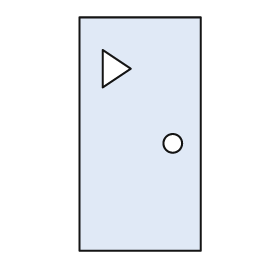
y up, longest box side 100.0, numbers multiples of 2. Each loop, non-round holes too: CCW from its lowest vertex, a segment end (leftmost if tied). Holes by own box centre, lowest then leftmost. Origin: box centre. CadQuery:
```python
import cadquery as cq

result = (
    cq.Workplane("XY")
    .moveTo(-26.0, -50.0)
    .lineTo(26.0, -50.0)
    .lineTo(26.0, 50.0)
    .lineTo(-26.0, 50.0)
    .close()
    .moveTo(14.0, -4.0)
    .circle(4.0)
    .moveTo(-16.0, 20.0)
    .lineTo(-4.0, 28.0)
    .lineTo(-16.0, 36.0)
    .close()
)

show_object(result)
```